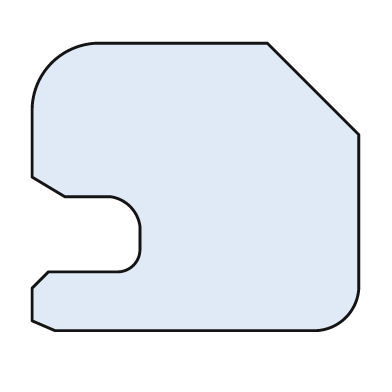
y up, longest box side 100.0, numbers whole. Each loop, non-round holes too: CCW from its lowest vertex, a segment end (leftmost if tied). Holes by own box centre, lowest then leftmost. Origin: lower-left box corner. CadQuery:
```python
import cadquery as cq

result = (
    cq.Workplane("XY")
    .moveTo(7.0, 0.0)
    .lineTo(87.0, 0.0)
    .threePointArc((96.0, 4.0), (100.0, 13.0))
    .lineTo(100.0, 60.0)
    .lineTo(72.0, 88.0)
    .lineTo(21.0, 88.0)
    .threePointArc((6.0, 82.0), (0.0, 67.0))
    .lineTo(0.0, 47.0)
    .lineTo(10.0, 41.0)
    .lineTo(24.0, 41.0)
    .threePointArc((30.0, 38.0), (33.0, 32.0))
    .lineTo(33.0, 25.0)
    .threePointArc((31.0, 20.0), (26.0, 18.0))
    .lineTo(5.0, 18.0)
    .lineTo(0.0, 13.0)
    .lineTo(0.0, 3.0)
    .close()
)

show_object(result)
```